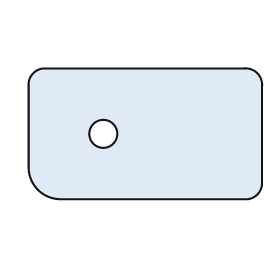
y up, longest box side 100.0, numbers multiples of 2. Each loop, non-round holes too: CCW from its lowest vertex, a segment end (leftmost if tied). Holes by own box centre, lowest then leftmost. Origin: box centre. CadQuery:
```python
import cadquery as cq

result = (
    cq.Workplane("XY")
    .moveTo(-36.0, -28.0)
    .lineTo(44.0, -28.0)
    .threePointArc((48.0, -26.0), (50.0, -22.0))
    .lineTo(50.0, 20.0)
    .threePointArc((48.0, 26.0), (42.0, 28.0))
    .lineTo(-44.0, 28.0)
    .threePointArc((-48.0, 26.0), (-50.0, 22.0))
    .lineTo(-50.0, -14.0)
    .threePointArc((-46.0, -24.0), (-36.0, -28.0))
    .close()
    .moveTo(-18.0, 0.0)
    .circle(6.0)
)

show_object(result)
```